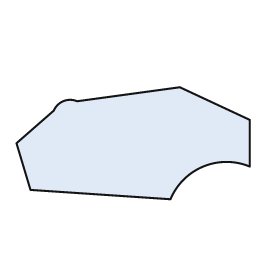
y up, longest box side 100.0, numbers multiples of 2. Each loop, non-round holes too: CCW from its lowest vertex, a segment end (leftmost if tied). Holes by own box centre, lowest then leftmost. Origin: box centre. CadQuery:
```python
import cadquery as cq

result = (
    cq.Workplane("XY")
    .moveTo(16.0, -24.0)
    .threePointArc((30.0, -10.0), (50.0, -10.0))
    .lineTo(50.0, 10.0)
    .lineTo(20.0, 24.0)
    .lineTo(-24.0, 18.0)
    .threePointArc((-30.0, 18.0), (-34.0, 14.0))
    .lineTo(-50.0, 0.0)
    .lineTo(-44.0, -20.0)
    .close()
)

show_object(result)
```